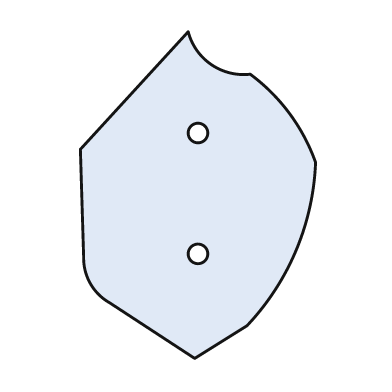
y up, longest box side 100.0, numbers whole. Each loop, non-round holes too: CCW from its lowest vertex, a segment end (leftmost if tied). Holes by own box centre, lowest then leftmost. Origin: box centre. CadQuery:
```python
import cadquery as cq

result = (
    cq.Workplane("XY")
    .moveTo(-1.0, -50.0)
    .lineTo(15.0, -40.0)
    .threePointArc((30.0, -17.0), (36.0, 10.0))
    .threePointArc((28.0, 25.0), (16.0, 37.0))
    .threePointArc((4.0, 40.0), (-3.0, 50.0))
    .lineTo(-36.0, 14.0)
    .lineTo(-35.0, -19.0)
    .threePointArc((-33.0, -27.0), (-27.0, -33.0))
    .close()
    .moveTo(0.0, -18.0)
    .circle(3.0)
    .moveTo(0.0, 19.0)
    .circle(3.0)
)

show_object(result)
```